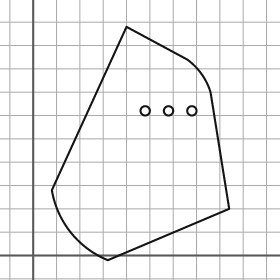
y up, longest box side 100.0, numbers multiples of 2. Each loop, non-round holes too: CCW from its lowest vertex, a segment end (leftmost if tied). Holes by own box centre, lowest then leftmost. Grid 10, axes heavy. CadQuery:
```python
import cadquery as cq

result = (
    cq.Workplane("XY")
    .moveTo(32.0, -2.0)
    .lineTo(84.0, 20.0)
    .lineTo(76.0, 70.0)
    .threePointArc((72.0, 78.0), (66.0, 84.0))
    .lineTo(40.0, 98.0)
    .lineTo(8.0, 28.0)
    .threePointArc((16.0, 10.0), (32.0, -2.0))
    .close()
    .moveTo(48.0, 62.0)
    .circle(2.0)
    .moveTo(58.0, 62.0)
    .circle(2.0)
    .moveTo(68.0, 62.0)
    .circle(2.0)
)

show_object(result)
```